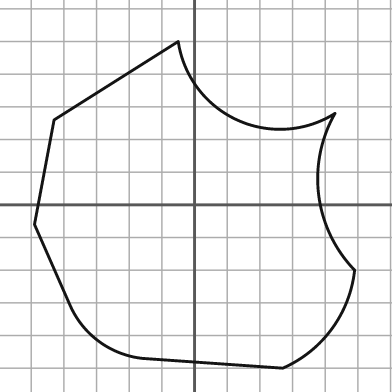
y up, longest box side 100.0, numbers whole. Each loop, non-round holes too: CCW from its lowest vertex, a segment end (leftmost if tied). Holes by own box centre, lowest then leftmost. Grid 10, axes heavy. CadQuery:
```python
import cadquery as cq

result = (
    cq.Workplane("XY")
    .moveTo(27.0, -50.0)
    .threePointArc((42.0, -38.0), (49.0, -20.0))
    .threePointArc((38.0, 3.0), (43.0, 28.0))
    .threePointArc((13.0, 26.0), (-5.0, 50.0))
    .lineTo(-43.0, 26.0)
    .lineTo(-49.0, -6.0)
    .lineTo(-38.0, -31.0)
    .threePointArc((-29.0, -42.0), (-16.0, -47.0))
    .close()
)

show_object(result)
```